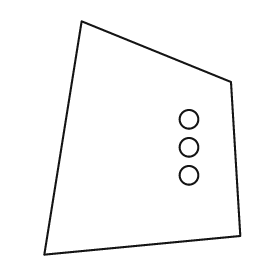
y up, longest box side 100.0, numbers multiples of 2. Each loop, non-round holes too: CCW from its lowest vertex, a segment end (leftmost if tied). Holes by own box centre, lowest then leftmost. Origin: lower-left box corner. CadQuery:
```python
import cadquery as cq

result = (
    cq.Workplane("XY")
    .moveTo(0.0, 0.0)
    .lineTo(84.0, 8.0)
    .lineTo(80.0, 74.0)
    .lineTo(16.0, 100.0)
    .close()
    .moveTo(62.0, 34.0)
    .circle(4.0)
    .moveTo(62.0, 46.0)
    .circle(4.0)
    .moveTo(62.0, 58.0)
    .circle(4.0)
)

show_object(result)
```